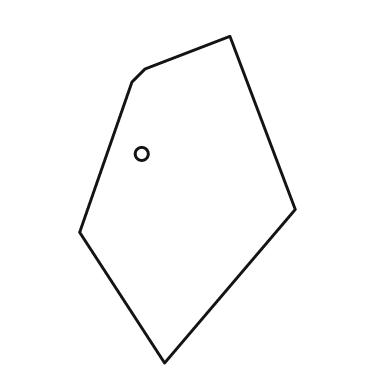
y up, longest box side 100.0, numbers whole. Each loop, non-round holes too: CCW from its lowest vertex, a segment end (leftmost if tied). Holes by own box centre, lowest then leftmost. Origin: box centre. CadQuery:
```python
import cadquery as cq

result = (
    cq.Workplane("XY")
    .moveTo(-7.0, -50.0)
    .lineTo(33.0, -3.0)
    .lineTo(13.0, 50.0)
    .lineTo(-13.0, 40.0)
    .lineTo(-17.0, 36.0)
    .lineTo(-33.0, -10.0)
    .close()
    .moveTo(-14.0, 14.0)
    .circle(2.0)
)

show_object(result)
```